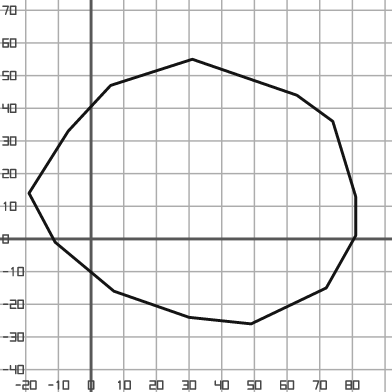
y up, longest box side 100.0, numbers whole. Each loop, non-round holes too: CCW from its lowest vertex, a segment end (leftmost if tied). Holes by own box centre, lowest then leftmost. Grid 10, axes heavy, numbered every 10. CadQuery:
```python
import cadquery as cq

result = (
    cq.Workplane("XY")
    .moveTo(49.0, -26.0)
    .lineTo(72.0, -15.0)
    .lineTo(81.0, 1.0)
    .lineTo(81.0, 13.0)
    .lineTo(74.0, 36.0)
    .lineTo(63.0, 44.0)
    .lineTo(31.0, 55.0)
    .lineTo(6.0, 47.0)
    .lineTo(-7.0, 33.0)
    .lineTo(-19.0, 14.0)
    .lineTo(-11.0, -1.0)
    .lineTo(7.0, -16.0)
    .lineTo(30.0, -24.0)
    .close()
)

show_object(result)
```